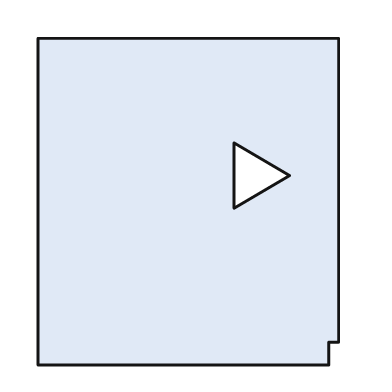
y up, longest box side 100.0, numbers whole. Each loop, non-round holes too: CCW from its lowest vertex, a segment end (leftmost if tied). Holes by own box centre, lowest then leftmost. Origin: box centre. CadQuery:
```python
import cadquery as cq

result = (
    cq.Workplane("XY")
    .moveTo(-46.0, -50.0)
    .lineTo(43.0, -50.0)
    .lineTo(43.0, -43.0)
    .lineTo(46.0, -43.0)
    .lineTo(46.0, 50.0)
    .lineTo(-46.0, 50.0)
    .close()
    .moveTo(14.0, -2.0)
    .lineTo(31.0, 8.0)
    .lineTo(14.0, 18.0)
    .close()
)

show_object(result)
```